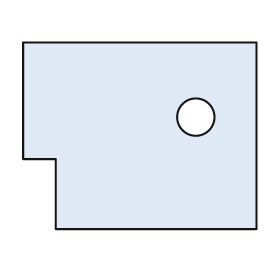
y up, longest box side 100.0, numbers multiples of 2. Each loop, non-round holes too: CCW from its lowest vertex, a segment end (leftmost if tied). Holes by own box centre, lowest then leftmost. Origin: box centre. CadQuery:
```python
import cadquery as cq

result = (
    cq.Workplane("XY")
    .moveTo(-36.0, -40.0)
    .lineTo(50.0, -40.0)
    .lineTo(50.0, 40.0)
    .lineTo(-50.0, 40.0)
    .lineTo(-50.0, -10.0)
    .lineTo(-36.0, -10.0)
    .close()
    .moveTo(24.0, 8.0)
    .circle(8.0)
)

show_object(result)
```